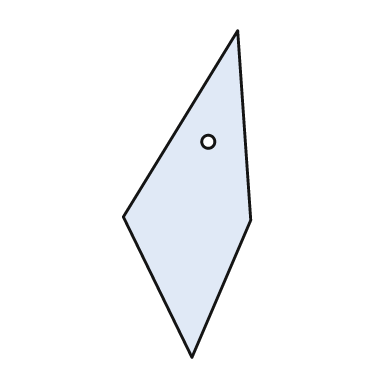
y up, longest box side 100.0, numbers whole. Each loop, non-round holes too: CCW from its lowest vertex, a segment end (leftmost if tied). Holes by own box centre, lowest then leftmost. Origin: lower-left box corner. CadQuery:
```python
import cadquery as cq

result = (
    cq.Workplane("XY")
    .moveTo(21.0, 0.0)
    .lineTo(39.0, 42.0)
    .lineTo(35.0, 100.0)
    .lineTo(0.0, 43.0)
    .close()
    .moveTo(26.0, 66.0)
    .circle(2.0)
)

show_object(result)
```